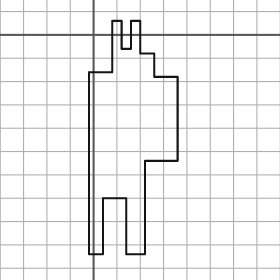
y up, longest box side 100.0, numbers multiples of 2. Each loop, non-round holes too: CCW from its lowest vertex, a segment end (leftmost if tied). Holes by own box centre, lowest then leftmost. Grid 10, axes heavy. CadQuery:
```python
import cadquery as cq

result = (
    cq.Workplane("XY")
    .moveTo(-2.0, -94.0)
    .lineTo(4.0, -94.0)
    .lineTo(4.0, -70.0)
    .lineTo(14.0, -70.0)
    .lineTo(14.0, -94.0)
    .lineTo(22.0, -94.0)
    .lineTo(22.0, -54.0)
    .lineTo(36.0, -54.0)
    .lineTo(36.0, -18.0)
    .lineTo(26.0, -18.0)
    .lineTo(26.0, -8.0)
    .lineTo(20.0, -8.0)
    .lineTo(20.0, 6.0)
    .lineTo(16.0, 6.0)
    .lineTo(16.0, -6.0)
    .lineTo(12.0, -6.0)
    .lineTo(12.0, 6.0)
    .lineTo(8.0, 6.0)
    .lineTo(8.0, -16.0)
    .lineTo(-2.0, -16.0)
    .close()
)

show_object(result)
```